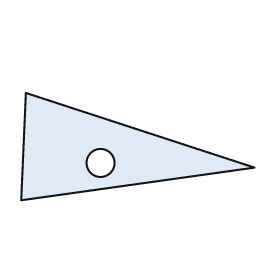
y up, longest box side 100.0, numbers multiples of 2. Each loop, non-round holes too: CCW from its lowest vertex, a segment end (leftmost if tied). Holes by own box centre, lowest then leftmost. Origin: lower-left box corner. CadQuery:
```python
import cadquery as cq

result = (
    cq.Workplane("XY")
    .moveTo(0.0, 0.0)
    .lineTo(100.0, 14.0)
    .lineTo(2.0, 46.0)
    .close()
    .moveTo(34.0, 16.0)
    .circle(6.0)
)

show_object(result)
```